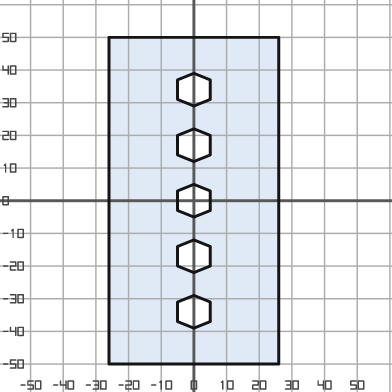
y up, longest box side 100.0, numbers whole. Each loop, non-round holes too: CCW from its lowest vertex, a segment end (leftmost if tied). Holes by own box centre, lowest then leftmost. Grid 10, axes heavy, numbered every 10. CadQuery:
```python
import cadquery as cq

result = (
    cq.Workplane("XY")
    .moveTo(-26.0, -50.0)
    .lineTo(26.0, -50.0)
    .lineTo(26.0, 50.0)
    .lineTo(-26.0, 50.0)
    .close()
    .moveTo(0.0, -39.0)
    .lineTo(5.0, -37.0)
    .lineTo(5.0, -31.0)
    .lineTo(0.0, -29.0)
    .lineTo(-5.0, -31.0)
    .lineTo(-5.0, -37.0)
    .close()
    .moveTo(0.0, -22.0)
    .lineTo(5.0, -20.0)
    .lineTo(5.0, -14.0)
    .lineTo(0.0, -12.0)
    .lineTo(-5.0, -14.0)
    .lineTo(-5.0, -20.0)
    .close()
    .moveTo(0.0, -5.0)
    .lineTo(5.0, -3.0)
    .lineTo(5.0, 3.0)
    .lineTo(0.0, 5.0)
    .lineTo(-5.0, 3.0)
    .lineTo(-5.0, -3.0)
    .close()
    .moveTo(0.0, 12.0)
    .lineTo(5.0, 14.0)
    .lineTo(5.0, 20.0)
    .lineTo(0.0, 22.0)
    .lineTo(-5.0, 20.0)
    .lineTo(-5.0, 14.0)
    .close()
    .moveTo(0.0, 29.0)
    .lineTo(5.0, 31.0)
    .lineTo(5.0, 37.0)
    .lineTo(0.0, 39.0)
    .lineTo(-5.0, 37.0)
    .lineTo(-5.0, 31.0)
    .close()
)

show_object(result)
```